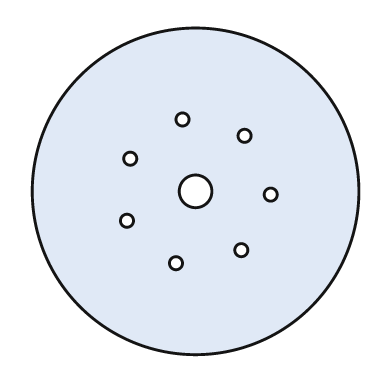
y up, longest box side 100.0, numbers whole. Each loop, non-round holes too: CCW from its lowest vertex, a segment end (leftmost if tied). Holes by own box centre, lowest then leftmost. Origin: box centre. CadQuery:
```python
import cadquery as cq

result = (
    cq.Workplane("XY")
    .moveTo(0.0, 0.0)
    .circle(50.0)
    .moveTo(-6.0, -22.0)
    .circle(2.0)
    .moveTo(14.0, -18.0)
    .circle(2.0)
    .moveTo(-21.0, -9.0)
    .circle(2.0)
    .moveTo(23.0, -1.0)
    .circle(2.0)
    .moveTo(0.0, 0.0)
    .circle(5.0)
    .moveTo(-20.0, 10.0)
    .circle(2.0)
    .moveTo(15.0, 17.0)
    .circle(2.0)
    .moveTo(-4.0, 22.0)
    .circle(2.0)
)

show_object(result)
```